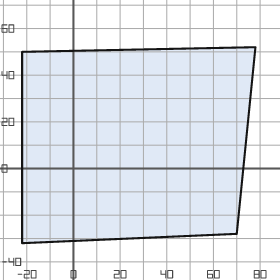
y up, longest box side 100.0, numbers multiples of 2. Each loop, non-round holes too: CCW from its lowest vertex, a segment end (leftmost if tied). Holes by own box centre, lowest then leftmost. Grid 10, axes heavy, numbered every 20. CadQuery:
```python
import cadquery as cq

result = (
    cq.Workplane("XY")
    .moveTo(-22.0, -32.0)
    .lineTo(70.0, -28.0)
    .lineTo(78.0, 52.0)
    .lineTo(-22.0, 50.0)
    .close()
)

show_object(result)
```